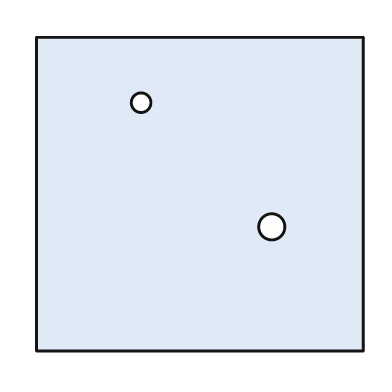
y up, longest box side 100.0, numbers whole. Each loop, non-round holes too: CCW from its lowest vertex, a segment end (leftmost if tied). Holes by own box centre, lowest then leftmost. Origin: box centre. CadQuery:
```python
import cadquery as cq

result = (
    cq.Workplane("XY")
    .moveTo(-50.0, -48.0)
    .lineTo(50.0, -48.0)
    .lineTo(50.0, 48.0)
    .lineTo(-50.0, 48.0)
    .close()
    .moveTo(22.0, -10.0)
    .circle(4.0)
    .moveTo(-18.0, 28.0)
    .circle(3.0)
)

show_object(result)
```